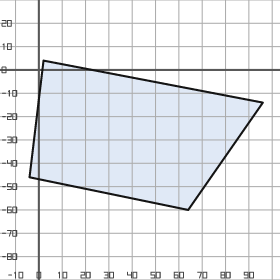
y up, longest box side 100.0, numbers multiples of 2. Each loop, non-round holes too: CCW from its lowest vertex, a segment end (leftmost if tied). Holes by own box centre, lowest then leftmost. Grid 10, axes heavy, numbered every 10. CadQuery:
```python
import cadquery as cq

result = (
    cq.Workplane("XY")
    .moveTo(64.0, -60.0)
    .lineTo(96.0, -14.0)
    .lineTo(2.0, 4.0)
    .lineTo(-4.0, -46.0)
    .close()
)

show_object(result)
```